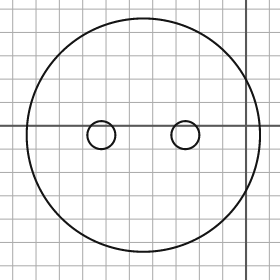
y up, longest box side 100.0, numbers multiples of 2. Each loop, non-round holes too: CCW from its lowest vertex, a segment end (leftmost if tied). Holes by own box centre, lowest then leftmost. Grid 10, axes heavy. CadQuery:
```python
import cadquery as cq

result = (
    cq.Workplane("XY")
    .moveTo(-44.0, -4.0)
    .circle(50.0)
    .moveTo(-62.0, -4.0)
    .circle(6.0)
    .moveTo(-26.0, -4.0)
    .circle(6.0)
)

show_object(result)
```